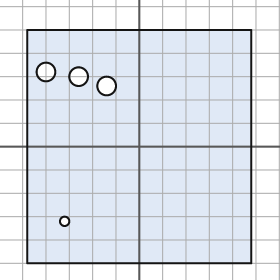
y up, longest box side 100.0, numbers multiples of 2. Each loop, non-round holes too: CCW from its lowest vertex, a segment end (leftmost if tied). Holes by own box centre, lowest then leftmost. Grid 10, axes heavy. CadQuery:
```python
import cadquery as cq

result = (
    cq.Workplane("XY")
    .moveTo(-48.0, -50.0)
    .lineTo(48.0, -50.0)
    .lineTo(48.0, 50.0)
    .lineTo(-48.0, 50.0)
    .close()
    .moveTo(-32.0, -32.0)
    .circle(2.0)
    .moveTo(-14.0, 26.0)
    .circle(4.0)
    .moveTo(-26.0, 30.0)
    .circle(4.0)
    .moveTo(-40.0, 32.0)
    .circle(4.0)
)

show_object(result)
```